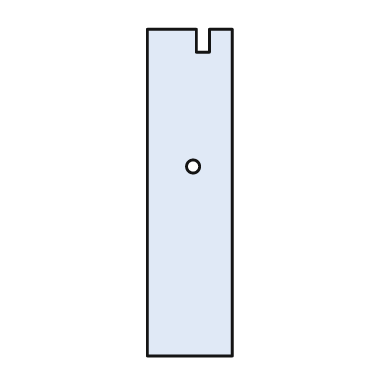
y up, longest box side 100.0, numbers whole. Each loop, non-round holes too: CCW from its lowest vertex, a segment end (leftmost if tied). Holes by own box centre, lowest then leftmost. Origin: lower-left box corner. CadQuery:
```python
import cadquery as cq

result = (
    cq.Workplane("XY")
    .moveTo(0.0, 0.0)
    .lineTo(26.0, 0.0)
    .lineTo(26.0, 100.0)
    .lineTo(19.0, 100.0)
    .lineTo(19.0, 93.0)
    .lineTo(15.0, 93.0)
    .lineTo(15.0, 100.0)
    .lineTo(0.0, 100.0)
    .close()
    .moveTo(14.0, 58.0)
    .circle(2.0)
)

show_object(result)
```